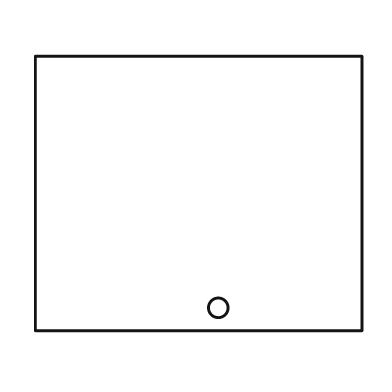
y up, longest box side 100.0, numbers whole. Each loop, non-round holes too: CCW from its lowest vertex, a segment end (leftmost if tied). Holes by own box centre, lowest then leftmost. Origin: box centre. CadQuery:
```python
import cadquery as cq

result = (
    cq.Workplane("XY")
    .moveTo(-50.0, -42.0)
    .lineTo(50.0, -42.0)
    .lineTo(50.0, 42.0)
    .lineTo(-50.0, 42.0)
    .close()
    .moveTo(6.0, -35.0)
    .circle(3.0)
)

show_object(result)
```